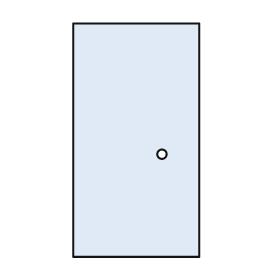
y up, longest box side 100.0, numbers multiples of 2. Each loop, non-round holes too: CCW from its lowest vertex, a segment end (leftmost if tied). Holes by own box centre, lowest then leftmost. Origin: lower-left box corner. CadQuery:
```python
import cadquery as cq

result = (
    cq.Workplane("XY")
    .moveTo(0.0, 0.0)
    .lineTo(54.0, 0.0)
    .lineTo(54.0, 100.0)
    .lineTo(0.0, 100.0)
    .close()
    .moveTo(38.0, 44.0)
    .circle(2.0)
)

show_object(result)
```